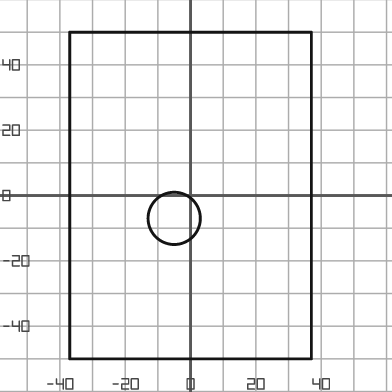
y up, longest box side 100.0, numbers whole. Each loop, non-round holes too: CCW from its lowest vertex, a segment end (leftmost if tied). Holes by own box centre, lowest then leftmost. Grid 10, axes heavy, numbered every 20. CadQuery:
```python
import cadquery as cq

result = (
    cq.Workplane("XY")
    .moveTo(-37.0, -50.0)
    .lineTo(37.0, -50.0)
    .lineTo(37.0, 50.0)
    .lineTo(-37.0, 50.0)
    .close()
    .moveTo(-5.0, -7.0)
    .circle(8.0)
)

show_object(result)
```